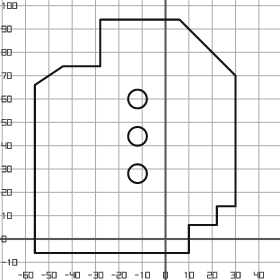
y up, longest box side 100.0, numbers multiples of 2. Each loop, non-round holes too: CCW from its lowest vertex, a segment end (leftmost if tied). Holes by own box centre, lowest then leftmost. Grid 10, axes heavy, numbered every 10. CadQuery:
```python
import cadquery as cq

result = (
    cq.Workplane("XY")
    .moveTo(-56.0, -6.0)
    .lineTo(10.0, -6.0)
    .lineTo(10.0, 6.0)
    .lineTo(22.0, 6.0)
    .lineTo(22.0, 14.0)
    .lineTo(30.0, 14.0)
    .lineTo(30.0, 70.0)
    .lineTo(6.0, 94.0)
    .lineTo(-28.0, 94.0)
    .lineTo(-28.0, 74.0)
    .lineTo(-44.0, 74.0)
    .lineTo(-56.0, 66.0)
    .close()
    .moveTo(-12.0, 28.0)
    .circle(4.0)
    .moveTo(-12.0, 44.0)
    .circle(4.0)
    .moveTo(-12.0, 60.0)
    .circle(4.0)
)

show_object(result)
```